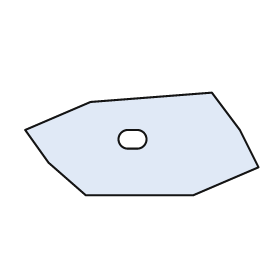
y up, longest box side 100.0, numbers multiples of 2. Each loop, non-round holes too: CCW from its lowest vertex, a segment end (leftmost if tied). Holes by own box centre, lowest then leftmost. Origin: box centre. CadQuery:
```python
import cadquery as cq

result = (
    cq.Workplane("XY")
    .moveTo(-24.0, -22.0)
    .lineTo(22.0, -22.0)
    .lineTo(50.0, -10.0)
    .lineTo(42.0, 6.0)
    .lineTo(30.0, 22.0)
    .lineTo(-22.0, 18.0)
    .lineTo(-50.0, 6.0)
    .lineTo(-40.0, -8.0)
    .close()
    .moveTo(-6.0, -2.0)
    .lineTo(-2.0, -2.0)
    .threePointArc((2.0, 2.0), (-2.0, 6.0))
    .lineTo(-6.0, 6.0)
    .threePointArc((-10.0, 2.0), (-6.0, -2.0))
    .close()
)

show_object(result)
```